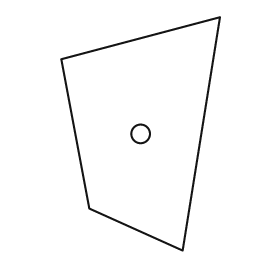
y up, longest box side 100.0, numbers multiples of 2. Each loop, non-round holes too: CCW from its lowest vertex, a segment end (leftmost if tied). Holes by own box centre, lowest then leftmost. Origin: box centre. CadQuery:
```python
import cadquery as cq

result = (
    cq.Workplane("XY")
    .moveTo(18.0, -50.0)
    .lineTo(34.0, 50.0)
    .lineTo(-34.0, 32.0)
    .lineTo(-22.0, -32.0)
    .close()
    .moveTo(0.0, 0.0)
    .circle(4.0)
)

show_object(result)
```